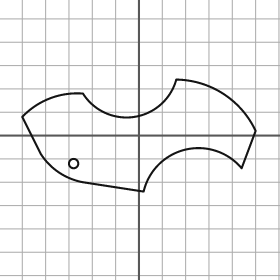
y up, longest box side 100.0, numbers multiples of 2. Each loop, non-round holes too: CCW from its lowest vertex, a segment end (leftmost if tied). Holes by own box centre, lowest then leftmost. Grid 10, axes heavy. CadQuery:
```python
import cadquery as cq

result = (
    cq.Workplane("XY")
    .moveTo(2.0, -24.0)
    .threePointArc((20.0, -6.0), (44.0, -14.0))
    .lineTo(50.0, 2.0)
    .threePointArc((36.0, 18.0), (16.0, 24.0))
    .threePointArc((-2.0, 8.0), (-24.0, 18.0))
    .threePointArc((-38.0, 16.0), (-50.0, 8.0))
    .lineTo(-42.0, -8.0)
    .threePointArc((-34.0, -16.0), (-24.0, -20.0))
    .close()
    .moveTo(-28.0, -12.0)
    .circle(2.0)
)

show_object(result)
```